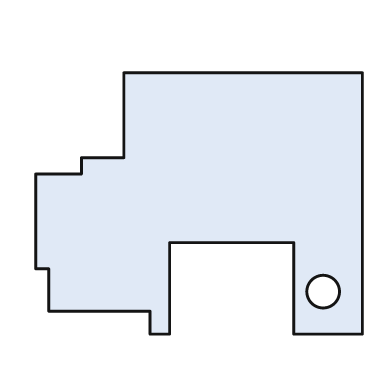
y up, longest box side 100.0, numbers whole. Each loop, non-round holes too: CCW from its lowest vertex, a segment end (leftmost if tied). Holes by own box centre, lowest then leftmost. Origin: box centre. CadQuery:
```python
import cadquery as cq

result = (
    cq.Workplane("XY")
    .moveTo(-15.0, -40.0)
    .lineTo(-9.0, -40.0)
    .lineTo(-9.0, -12.0)
    .lineTo(29.0, -12.0)
    .lineTo(29.0, -40.0)
    .lineTo(50.0, -40.0)
    .lineTo(50.0, 40.0)
    .lineTo(-23.0, 40.0)
    .lineTo(-23.0, 14.0)
    .lineTo(-36.0, 14.0)
    .lineTo(-36.0, 9.0)
    .lineTo(-50.0, 9.0)
    .lineTo(-50.0, -20.0)
    .lineTo(-46.0, -20.0)
    .lineTo(-46.0, -33.0)
    .lineTo(-15.0, -33.0)
    .close()
    .moveTo(38.0, -27.0)
    .circle(5.0)
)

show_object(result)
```